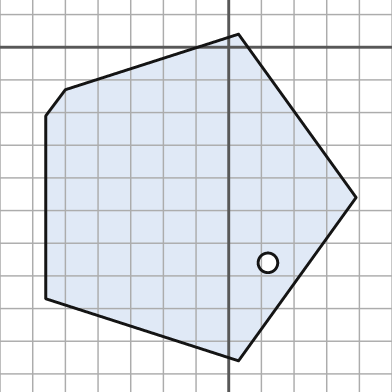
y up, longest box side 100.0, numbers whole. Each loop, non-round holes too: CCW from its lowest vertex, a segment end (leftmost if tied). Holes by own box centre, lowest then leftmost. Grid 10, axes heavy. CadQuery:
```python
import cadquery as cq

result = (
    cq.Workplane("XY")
    .moveTo(3.0, -96.0)
    .lineTo(39.0, -46.0)
    .lineTo(3.0, 4.0)
    .lineTo(-50.0, -13.0)
    .lineTo(-56.0, -21.0)
    .lineTo(-56.0, -77.0)
    .close()
    .moveTo(12.0, -66.0)
    .circle(3.0)
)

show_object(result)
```